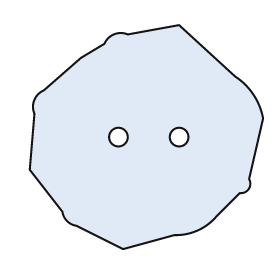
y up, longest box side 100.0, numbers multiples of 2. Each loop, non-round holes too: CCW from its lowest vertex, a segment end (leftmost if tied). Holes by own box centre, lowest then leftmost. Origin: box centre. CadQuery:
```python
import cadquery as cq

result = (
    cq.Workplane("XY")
    .moveTo(-10.0, -48.0)
    .lineTo(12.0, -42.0)
    .threePointArc((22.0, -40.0), (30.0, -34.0))
    .lineTo(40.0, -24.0)
    .threePointArc((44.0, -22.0), (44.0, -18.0))
    .lineTo(50.0, 8.0)
    .threePointArc((46.0, 18.0), (38.0, 26.0))
    .lineTo(14.0, 48.0)
    .lineTo(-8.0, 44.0)
    .threePointArc((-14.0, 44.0), (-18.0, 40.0))
    .lineTo(-28.0, 34.0)
    .lineTo(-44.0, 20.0)
    .threePointArc((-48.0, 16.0), (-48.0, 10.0))
    .lineTo(-50.0, -14.0)
    .lineTo(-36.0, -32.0)
    .threePointArc((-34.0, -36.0), (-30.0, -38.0))
    .close()
    .moveTo(-12.0, 0.0)
    .circle(4.0)
    .moveTo(14.0, 0.0)
    .circle(4.0)
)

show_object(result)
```